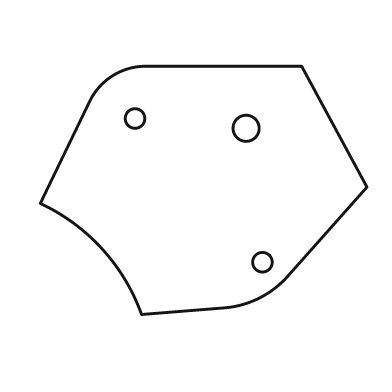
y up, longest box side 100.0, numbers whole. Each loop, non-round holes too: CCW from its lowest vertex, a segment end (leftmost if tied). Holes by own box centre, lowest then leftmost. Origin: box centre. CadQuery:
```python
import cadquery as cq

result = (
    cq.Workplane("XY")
    .moveTo(-19.0, -38.0)
    .lineTo(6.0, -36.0)
    .threePointArc((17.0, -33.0), (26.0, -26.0))
    .lineTo(50.0, 1.0)
    .lineTo(30.0, 38.0)
    .lineTo(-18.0, 38.0)
    .threePointArc((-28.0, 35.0), (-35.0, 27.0))
    .lineTo(-50.0, -4.0)
    .threePointArc((-31.0, -18.0), (-19.0, -38.0))
    .close()
    .moveTo(18.0, -22.0)
    .circle(3.0)
    .moveTo(13.0, 19.0)
    .circle(4.0)
    .moveTo(-21.0, 22.0)
    .circle(3.0)
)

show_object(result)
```